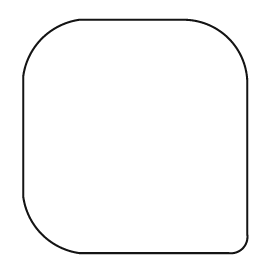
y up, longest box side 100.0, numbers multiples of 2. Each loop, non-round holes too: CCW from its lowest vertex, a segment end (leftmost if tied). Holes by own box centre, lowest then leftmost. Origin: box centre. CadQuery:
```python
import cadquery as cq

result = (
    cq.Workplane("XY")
    .moveTo(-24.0, -50.0)
    .lineTo(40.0, -50.0)
    .threePointArc((46.0, -48.0), (48.0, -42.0))
    .lineTo(48.0, 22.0)
    .threePointArc((40.0, 42.0), (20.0, 50.0))
    .lineTo(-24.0, 50.0)
    .threePointArc((-40.0, 42.0), (-48.0, 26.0))
    .lineTo(-48.0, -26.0)
    .threePointArc((-40.0, -42.0), (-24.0, -50.0))
    .close()
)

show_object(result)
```